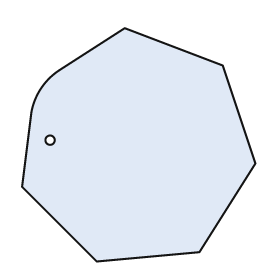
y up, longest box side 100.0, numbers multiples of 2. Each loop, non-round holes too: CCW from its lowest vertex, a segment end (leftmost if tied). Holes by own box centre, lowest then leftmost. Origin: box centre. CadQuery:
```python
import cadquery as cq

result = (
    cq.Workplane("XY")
    .moveTo(-18.0, -50.0)
    .lineTo(26.0, -46.0)
    .lineTo(50.0, -8.0)
    .lineTo(36.0, 34.0)
    .lineTo(-6.0, 50.0)
    .lineTo(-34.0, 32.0)
    .threePointArc((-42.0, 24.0), (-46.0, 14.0))
    .lineTo(-50.0, -18.0)
    .close()
    .moveTo(-38.0, 2.0)
    .circle(2.0)
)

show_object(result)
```